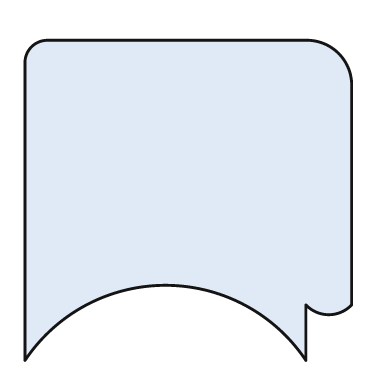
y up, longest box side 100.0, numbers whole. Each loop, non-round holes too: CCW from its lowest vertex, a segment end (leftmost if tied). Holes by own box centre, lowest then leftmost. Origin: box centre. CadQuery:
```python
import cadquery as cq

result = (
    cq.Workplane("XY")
    .moveTo(-50.0, -49.0)
    .threePointArc((-7.0, -26.0), (36.0, -49.0))
    .lineTo(36.0, -32.0)
    .threePointArc((43.0, -35.0), (50.0, -32.0))
    .lineTo(50.0, 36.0)
    .threePointArc((46.0, 45.0), (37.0, 49.0))
    .lineTo(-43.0, 49.0)
    .threePointArc((-48.0, 47.0), (-50.0, 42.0))
    .close()
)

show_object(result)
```